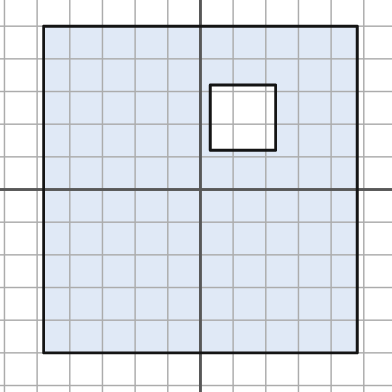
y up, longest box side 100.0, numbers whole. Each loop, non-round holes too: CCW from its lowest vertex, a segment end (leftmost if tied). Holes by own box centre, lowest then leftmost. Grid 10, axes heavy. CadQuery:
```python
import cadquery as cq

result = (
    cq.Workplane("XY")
    .moveTo(-48.0, -50.0)
    .lineTo(48.0, -50.0)
    .lineTo(48.0, 50.0)
    .lineTo(-48.0, 50.0)
    .close()
    .moveTo(3.0, 12.0)
    .lineTo(23.0, 12.0)
    .lineTo(23.0, 32.0)
    .lineTo(3.0, 32.0)
    .close()
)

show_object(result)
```